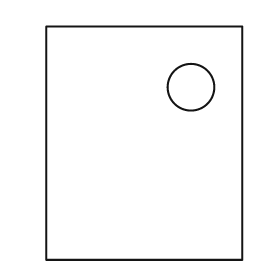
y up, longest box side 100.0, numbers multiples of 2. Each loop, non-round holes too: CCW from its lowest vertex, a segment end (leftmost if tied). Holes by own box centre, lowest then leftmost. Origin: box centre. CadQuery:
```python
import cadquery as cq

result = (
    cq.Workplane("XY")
    .moveTo(-42.0, -50.0)
    .lineTo(42.0, -50.0)
    .lineTo(42.0, 50.0)
    .lineTo(-42.0, 50.0)
    .close()
    .moveTo(20.0, 24.0)
    .circle(10.0)
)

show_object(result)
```